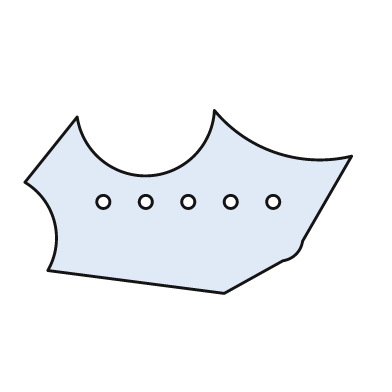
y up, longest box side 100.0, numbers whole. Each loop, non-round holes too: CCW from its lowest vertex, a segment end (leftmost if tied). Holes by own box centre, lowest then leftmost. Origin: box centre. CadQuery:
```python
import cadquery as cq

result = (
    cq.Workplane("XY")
    .moveTo(11.0, -28.0)
    .lineTo(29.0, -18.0)
    .threePointArc((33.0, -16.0), (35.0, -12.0))
    .lineTo(50.0, 14.0)
    .threePointArc((27.0, 15.0), (8.0, 28.0))
    .threePointArc((-12.0, 8.0), (-34.0, 26.0))
    .lineTo(-50.0, 6.0)
    .threePointArc((-41.0, -6.0), (-43.0, -21.0))
    .close()
    .moveTo(-26.0, 0.0)
    .circle(2.0)
    .moveTo(-13.0, 0.0)
    .circle(2.0)
    .moveTo(0.0, 0.0)
    .circle(2.0)
    .moveTo(13.0, 0.0)
    .circle(2.0)
    .moveTo(26.0, 0.0)
    .circle(2.0)
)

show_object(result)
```